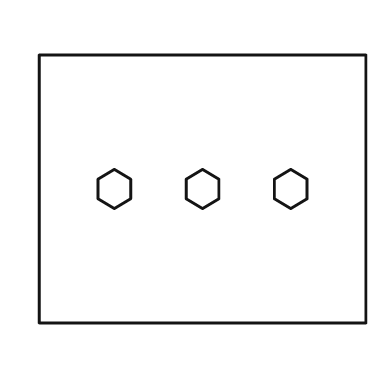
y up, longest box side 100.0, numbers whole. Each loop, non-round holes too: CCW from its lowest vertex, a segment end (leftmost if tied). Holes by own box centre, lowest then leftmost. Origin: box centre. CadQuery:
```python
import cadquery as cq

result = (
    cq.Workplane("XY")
    .moveTo(-50.0, -41.0)
    .lineTo(50.0, -41.0)
    .lineTo(50.0, 41.0)
    .lineTo(-50.0, 41.0)
    .close()
    .moveTo(-27.0, -6.0)
    .lineTo(-22.0, -3.0)
    .lineTo(-22.0, 3.0)
    .lineTo(-27.0, 6.0)
    .lineTo(-32.0, 3.0)
    .lineTo(-32.0, -3.0)
    .close()
    .moveTo(0.0, -6.0)
    .lineTo(5.0, -3.0)
    .lineTo(5.0, 3.0)
    .lineTo(0.0, 6.0)
    .lineTo(-5.0, 3.0)
    .lineTo(-5.0, -3.0)
    .close()
    .moveTo(27.0, -6.0)
    .lineTo(32.0, -3.0)
    .lineTo(32.0, 3.0)
    .lineTo(27.0, 6.0)
    .lineTo(22.0, 3.0)
    .lineTo(22.0, -3.0)
    .close()
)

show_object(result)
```